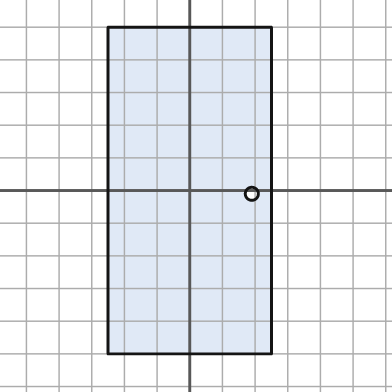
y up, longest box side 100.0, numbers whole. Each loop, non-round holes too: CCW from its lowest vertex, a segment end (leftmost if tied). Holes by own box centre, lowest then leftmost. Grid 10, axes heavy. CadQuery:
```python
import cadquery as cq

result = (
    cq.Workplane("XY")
    .moveTo(-25.0, -50.0)
    .lineTo(25.0, -50.0)
    .lineTo(25.0, 50.0)
    .lineTo(-25.0, 50.0)
    .close()
    .moveTo(19.0, -1.0)
    .circle(2.0)
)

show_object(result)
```